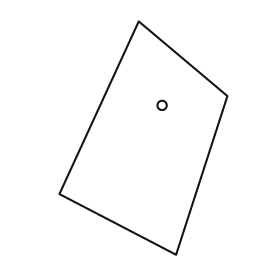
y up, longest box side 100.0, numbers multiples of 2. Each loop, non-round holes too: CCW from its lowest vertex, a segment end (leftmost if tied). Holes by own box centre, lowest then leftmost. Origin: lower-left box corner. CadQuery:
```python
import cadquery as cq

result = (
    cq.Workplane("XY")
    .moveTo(50.0, 0.0)
    .lineTo(72.0, 68.0)
    .lineTo(34.0, 100.0)
    .lineTo(0.0, 26.0)
    .close()
    .moveTo(44.0, 64.0)
    .circle(2.0)
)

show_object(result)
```